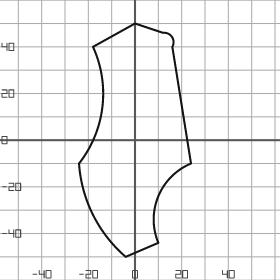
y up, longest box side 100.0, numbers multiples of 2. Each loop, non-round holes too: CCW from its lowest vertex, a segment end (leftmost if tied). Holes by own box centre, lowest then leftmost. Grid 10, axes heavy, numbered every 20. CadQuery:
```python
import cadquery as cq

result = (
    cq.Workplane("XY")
    .moveTo(-4.0, -50.0)
    .lineTo(10.0, -44.0)
    .threePointArc((10.0, -24.0), (24.0, -10.0))
    .lineTo(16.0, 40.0)
    .threePointArc((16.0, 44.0), (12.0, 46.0))
    .lineTo(0.0, 50.0)
    .lineTo(-18.0, 40.0)
    .threePointArc((-14.0, 14.0), (-24.0, -10.0))
    .threePointArc((-18.0, -32.0), (-4.0, -50.0))
    .close()
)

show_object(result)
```